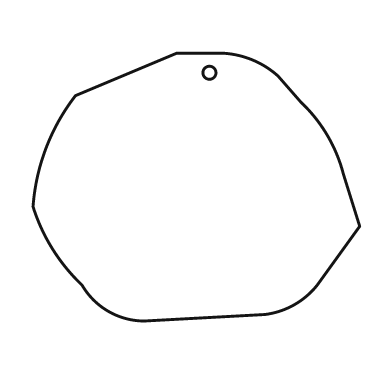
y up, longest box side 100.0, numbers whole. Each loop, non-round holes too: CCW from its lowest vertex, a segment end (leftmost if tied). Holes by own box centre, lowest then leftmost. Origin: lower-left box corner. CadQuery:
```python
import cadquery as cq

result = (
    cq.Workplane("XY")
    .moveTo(34.0, 0.0)
    .lineTo(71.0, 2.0)
    .threePointArc((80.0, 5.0), (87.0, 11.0))
    .lineTo(100.0, 29.0)
    .lineTo(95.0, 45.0)
    .threePointArc((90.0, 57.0), (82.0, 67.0))
    .lineTo(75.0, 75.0)
    .threePointArc((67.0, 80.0), (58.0, 82.0))
    .lineTo(44.0, 82.0)
    .lineTo(13.0, 69.0)
    .threePointArc((4.0, 53.0), (0.0, 35.0))
    .threePointArc((6.0, 22.0), (15.0, 11.0))
    .threePointArc((23.0, 3.0), (34.0, 0.0))
    .close()
    .moveTo(54.0, 76.0)
    .circle(2.0)
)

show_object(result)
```